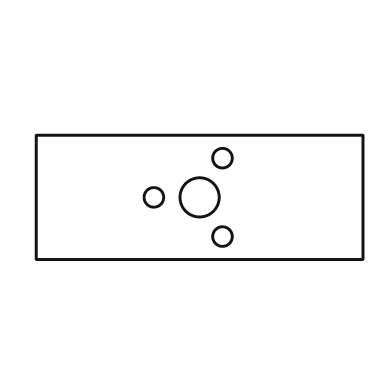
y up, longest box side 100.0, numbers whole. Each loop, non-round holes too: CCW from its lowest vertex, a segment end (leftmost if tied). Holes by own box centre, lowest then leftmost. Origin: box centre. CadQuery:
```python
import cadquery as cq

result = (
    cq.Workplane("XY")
    .moveTo(-50.0, -19.0)
    .lineTo(50.0, -19.0)
    .lineTo(50.0, 19.0)
    .lineTo(-50.0, 19.0)
    .close()
    .moveTo(7.0, -12.0)
    .circle(3.0)
    .moveTo(-14.0, 0.0)
    .circle(3.0)
    .moveTo(0.0, 0.0)
    .circle(6.0)
    .moveTo(7.0, 12.0)
    .circle(3.0)
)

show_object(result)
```